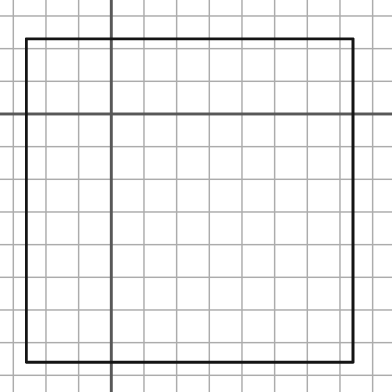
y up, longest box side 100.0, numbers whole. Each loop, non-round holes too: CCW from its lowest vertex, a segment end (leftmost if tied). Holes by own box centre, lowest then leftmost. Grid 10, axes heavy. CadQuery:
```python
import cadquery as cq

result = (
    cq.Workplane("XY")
    .moveTo(-26.0, -76.0)
    .lineTo(74.0, -76.0)
    .lineTo(74.0, 23.0)
    .lineTo(-26.0, 23.0)
    .close()
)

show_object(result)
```